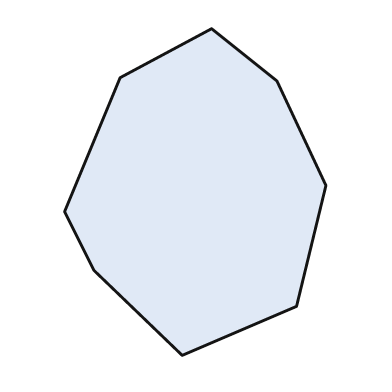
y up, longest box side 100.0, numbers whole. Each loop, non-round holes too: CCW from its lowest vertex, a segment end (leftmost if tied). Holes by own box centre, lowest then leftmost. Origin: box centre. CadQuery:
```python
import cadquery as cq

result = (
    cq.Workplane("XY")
    .moveTo(-4.0, -50.0)
    .lineTo(31.0, -35.0)
    .lineTo(40.0, 2.0)
    .lineTo(25.0, 34.0)
    .lineTo(5.0, 50.0)
    .lineTo(-23.0, 35.0)
    .lineTo(-40.0, -6.0)
    .lineTo(-31.0, -24.0)
    .close()
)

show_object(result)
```